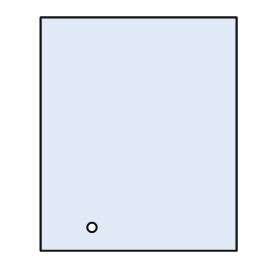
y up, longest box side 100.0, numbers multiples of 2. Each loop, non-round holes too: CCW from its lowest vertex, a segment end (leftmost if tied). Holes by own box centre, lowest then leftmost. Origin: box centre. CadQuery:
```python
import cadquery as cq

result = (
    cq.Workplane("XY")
    .moveTo(-42.0, -50.0)
    .lineTo(42.0, -50.0)
    .lineTo(42.0, 50.0)
    .lineTo(-42.0, 50.0)
    .close()
    .moveTo(-20.0, -40.0)
    .circle(2.0)
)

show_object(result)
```